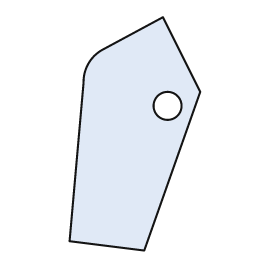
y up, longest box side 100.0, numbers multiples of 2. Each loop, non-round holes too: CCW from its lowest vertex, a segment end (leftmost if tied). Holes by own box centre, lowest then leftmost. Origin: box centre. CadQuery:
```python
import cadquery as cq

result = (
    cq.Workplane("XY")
    .moveTo(4.0, -50.0)
    .lineTo(28.0, 18.0)
    .lineTo(12.0, 50.0)
    .lineTo(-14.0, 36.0)
    .threePointArc((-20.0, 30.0), (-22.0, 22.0))
    .lineTo(-28.0, -46.0)
    .close()
    .moveTo(14.0, 12.0)
    .circle(6.0)
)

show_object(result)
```